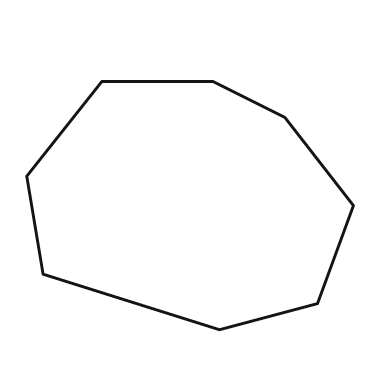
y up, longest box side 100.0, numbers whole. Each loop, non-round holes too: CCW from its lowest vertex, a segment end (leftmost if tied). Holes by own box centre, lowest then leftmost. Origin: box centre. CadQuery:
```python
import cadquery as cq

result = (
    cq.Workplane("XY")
    .moveTo(9.0, -38.0)
    .lineTo(39.0, -30.0)
    .lineTo(50.0, 0.0)
    .lineTo(29.0, 27.0)
    .lineTo(7.0, 38.0)
    .lineTo(-27.0, 38.0)
    .lineTo(-50.0, 9.0)
    .lineTo(-45.0, -21.0)
    .close()
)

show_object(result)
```